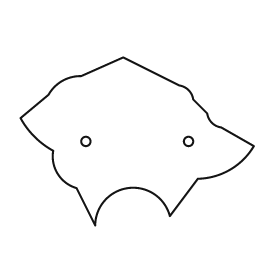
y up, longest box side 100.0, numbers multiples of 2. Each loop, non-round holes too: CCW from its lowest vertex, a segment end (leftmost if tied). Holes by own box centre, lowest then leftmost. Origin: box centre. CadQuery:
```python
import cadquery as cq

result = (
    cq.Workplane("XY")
    .moveTo(-18.0, -36.0)
    .threePointArc((-4.0, -20.0), (14.0, -32.0))
    .lineTo(26.0, -16.0)
    .threePointArc((40.0, -12.0), (50.0, -2.0))
    .lineTo(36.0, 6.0)
    .threePointArc((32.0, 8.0), (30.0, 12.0))
    .lineTo(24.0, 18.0)
    .threePointArc((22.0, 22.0), (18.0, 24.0))
    .lineTo(-6.0, 36.0)
    .lineTo(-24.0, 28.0)
    .threePointArc((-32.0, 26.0), (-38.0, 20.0))
    .lineTo(-50.0, 10.0)
    .threePointArc((-44.0, 2.0), (-36.0, -4.0))
    .threePointArc((-34.0, -14.0), (-26.0, -20.0))
    .close()
    .moveTo(-22.0, 0.0)
    .circle(2.0)
    .moveTo(22.0, 0.0)
    .circle(2.0)
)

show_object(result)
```